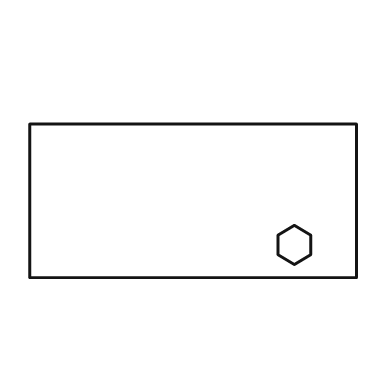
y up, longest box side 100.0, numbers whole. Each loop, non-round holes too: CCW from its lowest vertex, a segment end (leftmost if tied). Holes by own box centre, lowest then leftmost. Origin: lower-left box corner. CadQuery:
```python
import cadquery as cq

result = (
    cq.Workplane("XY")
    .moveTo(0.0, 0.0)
    .lineTo(100.0, 0.0)
    .lineTo(100.0, 47.0)
    .lineTo(0.0, 47.0)
    .close()
    .moveTo(81.0, 4.0)
    .lineTo(86.0, 7.0)
    .lineTo(86.0, 13.0)
    .lineTo(81.0, 16.0)
    .lineTo(76.0, 13.0)
    .lineTo(76.0, 7.0)
    .close()
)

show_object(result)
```